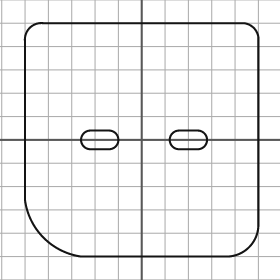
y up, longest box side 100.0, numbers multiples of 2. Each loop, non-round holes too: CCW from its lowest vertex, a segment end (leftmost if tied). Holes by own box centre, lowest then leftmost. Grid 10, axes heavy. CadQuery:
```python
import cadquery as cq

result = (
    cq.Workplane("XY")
    .moveTo(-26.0, -50.0)
    .lineTo(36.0, -50.0)
    .threePointArc((46.0, -46.0), (50.0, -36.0))
    .lineTo(50.0, 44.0)
    .threePointArc((48.0, 48.0), (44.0, 50.0))
    .lineTo(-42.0, 50.0)
    .threePointArc((-48.0, 48.0), (-50.0, 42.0))
    .lineTo(-50.0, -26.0)
    .threePointArc((-42.0, -42.0), (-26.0, -50.0))
    .close()
    .moveTo(-22.0, -4.0)
    .lineTo(-14.0, -4.0)
    .threePointArc((-10.0, 0.0), (-14.0, 4.0))
    .lineTo(-22.0, 4.0)
    .threePointArc((-26.0, 0.0), (-22.0, -4.0))
    .close()
    .moveTo(16.0, -4.0)
    .lineTo(24.0, -4.0)
    .threePointArc((28.0, 0.0), (24.0, 4.0))
    .lineTo(16.0, 4.0)
    .threePointArc((12.0, 0.0), (16.0, -4.0))
    .close()
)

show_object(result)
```